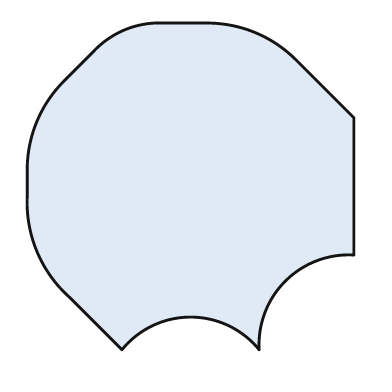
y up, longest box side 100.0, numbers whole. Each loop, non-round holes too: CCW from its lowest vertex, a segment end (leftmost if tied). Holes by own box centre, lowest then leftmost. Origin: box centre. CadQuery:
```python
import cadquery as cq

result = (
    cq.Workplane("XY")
    .moveTo(-21.0, -50.0)
    .threePointArc((0.0, -40.0), (21.0, -50.0))
    .threePointArc((29.0, -29.0), (50.0, -21.0))
    .lineTo(50.0, 21.0)
    .lineTo(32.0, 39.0)
    .threePointArc((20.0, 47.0), (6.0, 50.0))
    .lineTo(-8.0, 50.0)
    .threePointArc((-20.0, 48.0), (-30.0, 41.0))
    .lineTo(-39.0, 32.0)
    .threePointArc((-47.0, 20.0), (-50.0, 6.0))
    .lineTo(-50.0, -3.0)
    .threePointArc((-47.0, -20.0), (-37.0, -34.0))
    .close()
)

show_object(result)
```